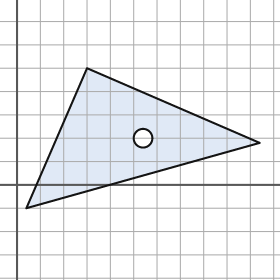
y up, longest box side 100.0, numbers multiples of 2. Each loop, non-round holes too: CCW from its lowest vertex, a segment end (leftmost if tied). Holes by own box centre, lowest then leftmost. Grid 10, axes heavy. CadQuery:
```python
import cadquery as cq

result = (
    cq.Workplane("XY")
    .moveTo(4.0, -10.0)
    .lineTo(104.0, 18.0)
    .lineTo(30.0, 50.0)
    .close()
    .moveTo(54.0, 20.0)
    .circle(4.0)
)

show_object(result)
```